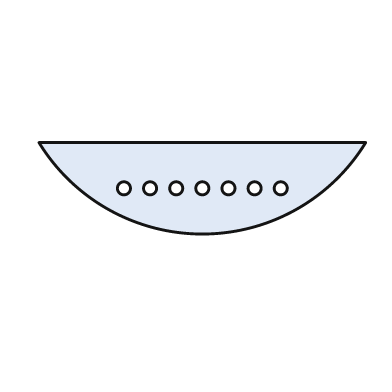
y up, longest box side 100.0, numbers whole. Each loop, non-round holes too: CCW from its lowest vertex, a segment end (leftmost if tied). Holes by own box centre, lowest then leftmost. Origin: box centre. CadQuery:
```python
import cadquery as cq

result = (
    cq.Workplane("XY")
    .moveTo(-50.0, 14.0)
    .threePointArc((0.0, -14.0), (50.0, 14.0))
    .close()
    .moveTo(-24.0, 0.0)
    .circle(2.0)
    .moveTo(-16.0, 0.0)
    .circle(2.0)
    .moveTo(-8.0, 0.0)
    .circle(2.0)
    .moveTo(0.0, 0.0)
    .circle(2.0)
    .moveTo(8.0, 0.0)
    .circle(2.0)
    .moveTo(16.0, 0.0)
    .circle(2.0)
    .moveTo(24.0, 0.0)
    .circle(2.0)
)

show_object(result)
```